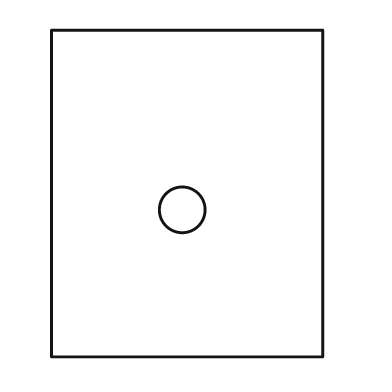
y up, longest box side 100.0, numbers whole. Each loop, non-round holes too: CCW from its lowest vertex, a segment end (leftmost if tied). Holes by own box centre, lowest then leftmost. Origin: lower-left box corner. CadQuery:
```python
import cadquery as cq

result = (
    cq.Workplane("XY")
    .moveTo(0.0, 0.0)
    .lineTo(83.0, 0.0)
    .lineTo(83.0, 100.0)
    .lineTo(0.0, 100.0)
    .close()
    .moveTo(40.0, 45.0)
    .circle(7.0)
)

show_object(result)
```